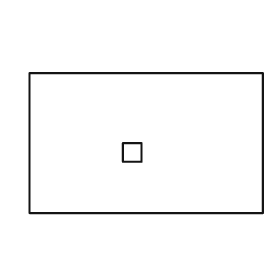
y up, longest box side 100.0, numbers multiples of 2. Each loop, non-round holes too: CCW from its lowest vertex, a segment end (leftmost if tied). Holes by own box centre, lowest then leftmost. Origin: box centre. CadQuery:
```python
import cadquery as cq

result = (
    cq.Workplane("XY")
    .moveTo(-50.0, -30.0)
    .lineTo(50.0, -30.0)
    .lineTo(50.0, 30.0)
    .lineTo(-50.0, 30.0)
    .close()
    .moveTo(-10.0, -8.0)
    .lineTo(-2.0, -8.0)
    .lineTo(-2.0, 0.0)
    .lineTo(-10.0, 0.0)
    .close()
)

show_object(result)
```